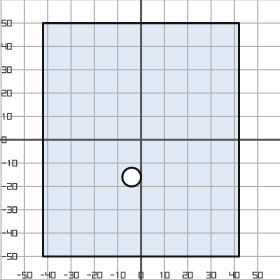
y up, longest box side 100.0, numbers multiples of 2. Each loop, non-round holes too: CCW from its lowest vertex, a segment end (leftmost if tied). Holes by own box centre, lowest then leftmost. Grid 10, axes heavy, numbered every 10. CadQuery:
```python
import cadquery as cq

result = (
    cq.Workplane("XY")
    .moveTo(-42.0, -50.0)
    .lineTo(42.0, -50.0)
    .lineTo(42.0, 50.0)
    .lineTo(-42.0, 50.0)
    .close()
    .moveTo(-4.0, -16.0)
    .circle(4.0)
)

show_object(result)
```